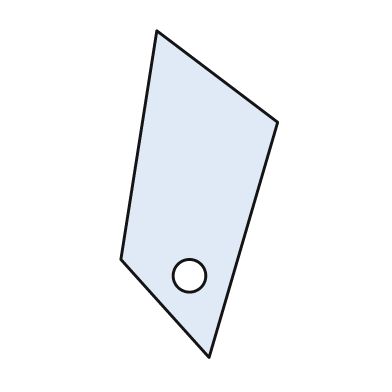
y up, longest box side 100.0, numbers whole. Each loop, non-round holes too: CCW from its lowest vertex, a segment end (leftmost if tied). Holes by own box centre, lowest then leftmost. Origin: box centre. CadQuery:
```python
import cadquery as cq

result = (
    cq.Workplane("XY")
    .moveTo(3.0, -50.0)
    .lineTo(24.0, 22.0)
    .lineTo(-13.0, 50.0)
    .lineTo(-24.0, -20.0)
    .close()
    .moveTo(-3.0, -25.0)
    .circle(5.0)
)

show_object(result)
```